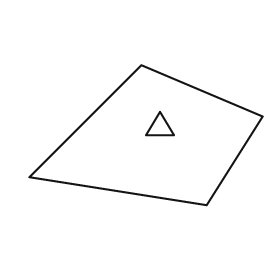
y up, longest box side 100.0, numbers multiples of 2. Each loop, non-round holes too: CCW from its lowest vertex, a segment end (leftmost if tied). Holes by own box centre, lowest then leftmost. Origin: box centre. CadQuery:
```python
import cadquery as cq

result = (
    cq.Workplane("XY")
    .moveTo(26.0, -30.0)
    .lineTo(50.0, 8.0)
    .lineTo(-2.0, 30.0)
    .lineTo(-50.0, -18.0)
    .close()
    .moveTo(0.0, 0.0)
    .lineTo(12.0, 0.0)
    .lineTo(6.0, 10.0)
    .close()
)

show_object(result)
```